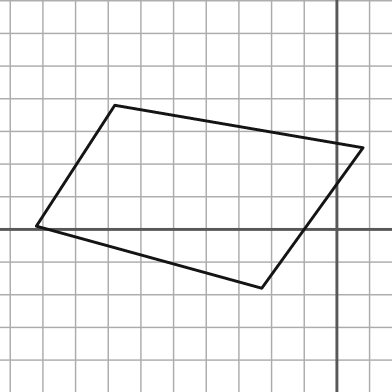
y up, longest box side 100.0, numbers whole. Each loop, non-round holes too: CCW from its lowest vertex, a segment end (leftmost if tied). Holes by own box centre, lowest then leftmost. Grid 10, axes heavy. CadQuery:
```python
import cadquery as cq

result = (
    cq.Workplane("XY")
    .moveTo(-23.0, -18.0)
    .lineTo(8.0, 25.0)
    .lineTo(-68.0, 38.0)
    .lineTo(-92.0, 1.0)
    .close()
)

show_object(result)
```